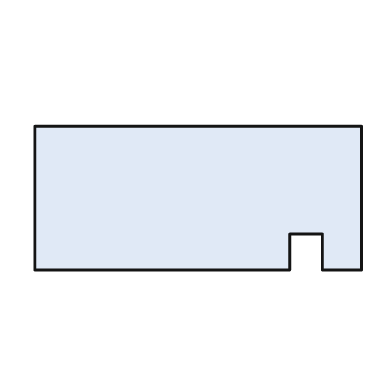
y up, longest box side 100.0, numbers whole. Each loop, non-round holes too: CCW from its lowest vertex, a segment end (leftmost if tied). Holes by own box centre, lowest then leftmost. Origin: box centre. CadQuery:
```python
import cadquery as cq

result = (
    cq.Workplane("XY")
    .moveTo(-50.0, -22.0)
    .lineTo(28.0, -22.0)
    .lineTo(28.0, -11.0)
    .lineTo(38.0, -11.0)
    .lineTo(38.0, -22.0)
    .lineTo(50.0, -22.0)
    .lineTo(50.0, 22.0)
    .lineTo(-50.0, 22.0)
    .close()
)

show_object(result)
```